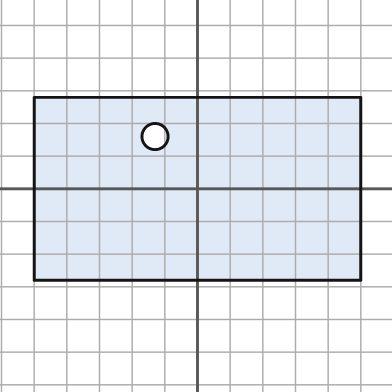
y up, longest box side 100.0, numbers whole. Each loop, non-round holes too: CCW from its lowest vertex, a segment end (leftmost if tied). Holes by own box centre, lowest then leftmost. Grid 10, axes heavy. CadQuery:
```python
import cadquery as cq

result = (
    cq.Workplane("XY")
    .moveTo(-50.0, -28.0)
    .lineTo(50.0, -28.0)
    .lineTo(50.0, 28.0)
    .lineTo(-50.0, 28.0)
    .close()
    .moveTo(-13.0, 16.0)
    .circle(4.0)
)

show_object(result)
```